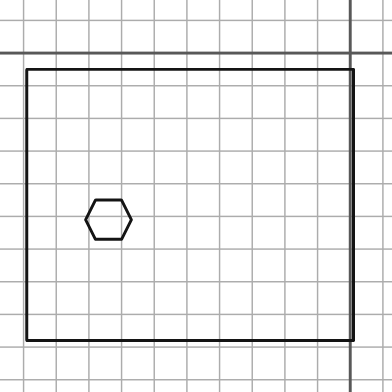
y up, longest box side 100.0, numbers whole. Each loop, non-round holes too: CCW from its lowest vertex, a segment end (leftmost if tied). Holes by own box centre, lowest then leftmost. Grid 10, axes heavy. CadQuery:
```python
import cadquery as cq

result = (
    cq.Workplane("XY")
    .moveTo(-99.0, -88.0)
    .lineTo(1.0, -88.0)
    .lineTo(1.0, -5.0)
    .lineTo(-99.0, -5.0)
    .close()
    .moveTo(-78.0, -57.0)
    .lineTo(-70.0, -57.0)
    .lineTo(-67.0, -51.0)
    .lineTo(-70.0, -45.0)
    .lineTo(-78.0, -45.0)
    .lineTo(-81.0, -51.0)
    .close()
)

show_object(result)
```